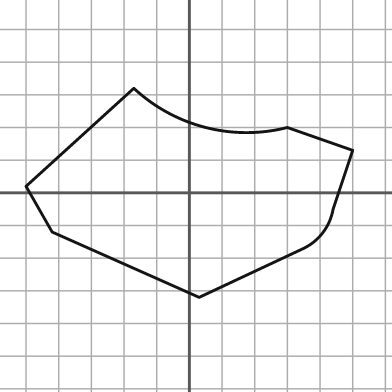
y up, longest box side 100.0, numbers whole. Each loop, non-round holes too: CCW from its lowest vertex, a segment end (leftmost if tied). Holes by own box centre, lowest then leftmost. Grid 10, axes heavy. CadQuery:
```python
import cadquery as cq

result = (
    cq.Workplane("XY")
    .moveTo(3.0, -32.0)
    .lineTo(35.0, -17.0)
    .threePointArc((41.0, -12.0), (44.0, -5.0))
    .lineTo(50.0, 13.0)
    .lineTo(30.0, 20.0)
    .threePointArc((5.0, 20.0), (-17.0, 32.0))
    .lineTo(-50.0, 2.0)
    .lineTo(-42.0, -12.0)
    .close()
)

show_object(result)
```